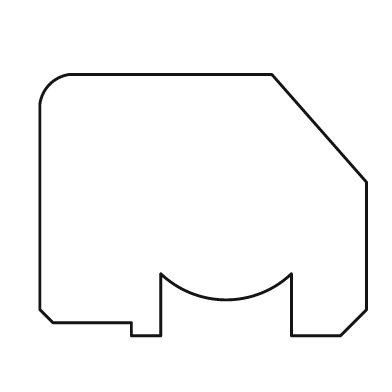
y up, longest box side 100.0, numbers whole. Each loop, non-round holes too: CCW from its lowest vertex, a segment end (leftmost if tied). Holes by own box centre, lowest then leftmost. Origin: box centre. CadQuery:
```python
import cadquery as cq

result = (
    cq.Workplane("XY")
    .moveTo(-22.0, -40.0)
    .lineTo(-13.0, -40.0)
    .lineTo(-13.0, -21.0)
    .threePointArc((7.0, -29.0), (27.0, -21.0))
    .lineTo(27.0, -40.0)
    .lineTo(42.0, -40.0)
    .lineTo(50.0, -32.0)
    .lineTo(50.0, 7.0)
    .lineTo(21.0, 40.0)
    .lineTo(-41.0, 40.0)
    .threePointArc((-47.0, 37.0), (-50.0, 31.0))
    .lineTo(-50.0, -32.0)
    .lineTo(-46.0, -36.0)
    .lineTo(-22.0, -36.0)
    .close()
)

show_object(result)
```